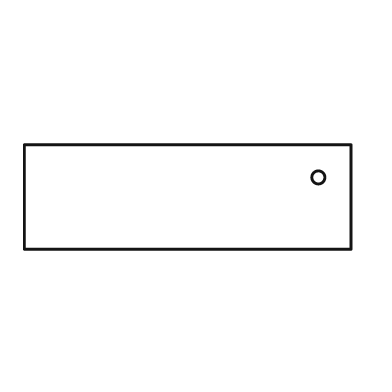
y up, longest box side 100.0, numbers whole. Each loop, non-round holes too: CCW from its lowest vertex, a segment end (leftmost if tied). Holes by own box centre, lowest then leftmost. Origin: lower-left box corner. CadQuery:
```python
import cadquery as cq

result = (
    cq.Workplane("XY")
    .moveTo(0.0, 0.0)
    .lineTo(100.0, 0.0)
    .lineTo(100.0, 32.0)
    .lineTo(0.0, 32.0)
    .close()
    .moveTo(90.0, 22.0)
    .circle(2.0)
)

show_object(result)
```